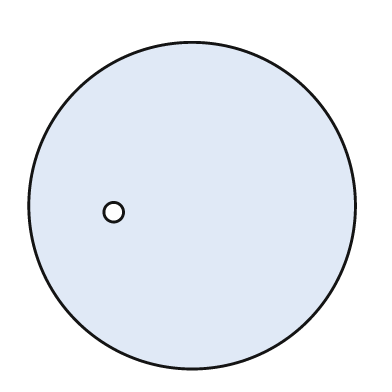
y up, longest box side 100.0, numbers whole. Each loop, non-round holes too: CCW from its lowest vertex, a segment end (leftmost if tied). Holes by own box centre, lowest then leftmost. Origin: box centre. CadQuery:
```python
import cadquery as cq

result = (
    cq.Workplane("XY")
    .moveTo(0.0, 0.0)
    .circle(50.0)
    .moveTo(-24.0, -2.0)
    .circle(3.0)
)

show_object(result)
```